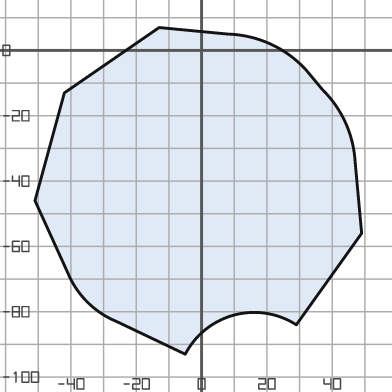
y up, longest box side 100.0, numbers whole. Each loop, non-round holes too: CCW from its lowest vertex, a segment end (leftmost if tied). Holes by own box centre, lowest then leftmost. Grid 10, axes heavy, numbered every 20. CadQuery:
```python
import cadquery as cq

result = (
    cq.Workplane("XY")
    .moveTo(-5.0, -93.0)
    .threePointArc((10.0, -81.0), (29.0, -84.0))
    .lineTo(49.0, -56.0)
    .lineTo(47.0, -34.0)
    .threePointArc((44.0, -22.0), (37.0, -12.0))
    .lineTo(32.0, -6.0)
    .threePointArc((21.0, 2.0), (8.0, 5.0))
    .lineTo(-13.0, 7.0)
    .lineTo(-42.0, -13.0)
    .lineTo(-51.0, -46.0)
    .lineTo(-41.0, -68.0)
    .threePointArc((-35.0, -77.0), (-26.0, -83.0))
    .close()
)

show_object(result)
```